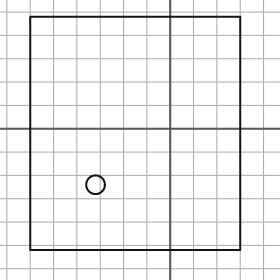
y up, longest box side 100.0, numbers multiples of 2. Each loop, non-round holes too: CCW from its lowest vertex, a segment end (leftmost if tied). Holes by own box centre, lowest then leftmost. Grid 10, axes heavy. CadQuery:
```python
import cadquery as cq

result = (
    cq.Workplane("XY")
    .moveTo(-60.0, -52.0)
    .lineTo(30.0, -52.0)
    .lineTo(30.0, 48.0)
    .lineTo(-60.0, 48.0)
    .close()
    .moveTo(-32.0, -24.0)
    .circle(4.0)
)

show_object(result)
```